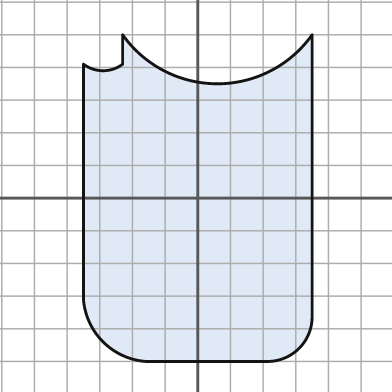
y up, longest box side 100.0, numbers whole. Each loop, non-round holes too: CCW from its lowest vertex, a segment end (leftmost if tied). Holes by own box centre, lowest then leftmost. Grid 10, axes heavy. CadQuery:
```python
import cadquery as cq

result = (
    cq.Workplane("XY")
    .moveTo(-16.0, -50.0)
    .lineTo(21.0, -50.0)
    .threePointArc((31.0, -46.0), (35.0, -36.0))
    .lineTo(35.0, 50.0)
    .threePointArc((6.0, 35.0), (-23.0, 50.0))
    .lineTo(-23.0, 41.0)
    .threePointArc((-29.0, 39.0), (-35.0, 41.0))
    .lineTo(-35.0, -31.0)
    .threePointArc((-29.0, -44.0), (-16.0, -50.0))
    .close()
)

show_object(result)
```